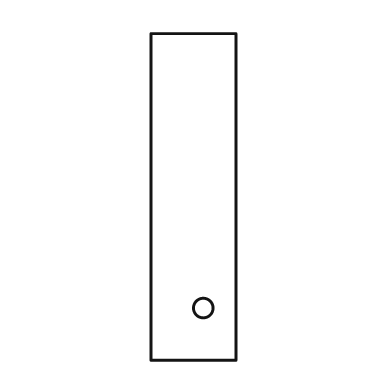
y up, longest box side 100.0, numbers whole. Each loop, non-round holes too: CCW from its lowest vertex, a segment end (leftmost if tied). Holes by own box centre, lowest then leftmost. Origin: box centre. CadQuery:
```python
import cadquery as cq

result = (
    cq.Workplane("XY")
    .moveTo(-13.0, -50.0)
    .lineTo(13.0, -50.0)
    .lineTo(13.0, 50.0)
    .lineTo(-13.0, 50.0)
    .close()
    .moveTo(3.0, -34.0)
    .circle(3.0)
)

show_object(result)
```